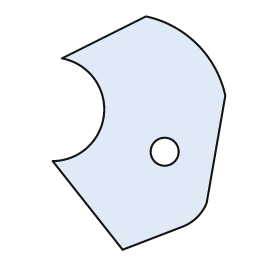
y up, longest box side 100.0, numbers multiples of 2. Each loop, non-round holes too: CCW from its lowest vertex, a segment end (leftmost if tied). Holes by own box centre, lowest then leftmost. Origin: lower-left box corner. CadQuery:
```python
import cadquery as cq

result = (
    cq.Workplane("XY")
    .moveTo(30.0, 0.0)
    .lineTo(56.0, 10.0)
    .threePointArc((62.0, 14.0), (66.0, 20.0))
    .lineTo(74.0, 66.0)
    .threePointArc((62.0, 88.0), (40.0, 100.0))
    .lineTo(4.0, 82.0)
    .threePointArc((22.0, 58.0), (0.0, 38.0))
    .close()
    .moveTo(48.0, 42.0)
    .circle(6.0)
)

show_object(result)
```